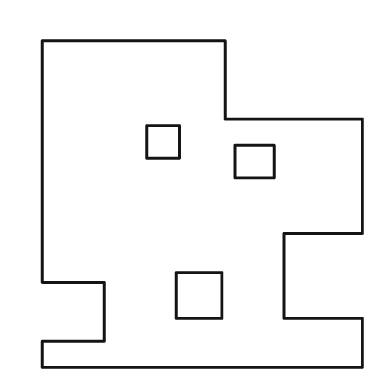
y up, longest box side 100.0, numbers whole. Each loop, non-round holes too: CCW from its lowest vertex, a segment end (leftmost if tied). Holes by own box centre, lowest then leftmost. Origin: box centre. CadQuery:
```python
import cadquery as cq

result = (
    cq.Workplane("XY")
    .moveTo(-49.0, -50.0)
    .lineTo(49.0, -50.0)
    .lineTo(49.0, -35.0)
    .lineTo(25.0, -35.0)
    .lineTo(25.0, -9.0)
    .lineTo(49.0, -9.0)
    .lineTo(49.0, 26.0)
    .lineTo(7.0, 26.0)
    .lineTo(7.0, 50.0)
    .lineTo(-49.0, 50.0)
    .lineTo(-49.0, -24.0)
    .lineTo(-30.0, -24.0)
    .lineTo(-30.0, -42.0)
    .lineTo(-49.0, -42.0)
    .close()
    .moveTo(-8.0, -35.0)
    .lineTo(6.0, -35.0)
    .lineTo(6.0, -21.0)
    .lineTo(-8.0, -21.0)
    .close()
    .moveTo(10.0, 8.0)
    .lineTo(22.0, 8.0)
    .lineTo(22.0, 18.0)
    .lineTo(10.0, 18.0)
    .close()
    .moveTo(-17.0, 14.0)
    .lineTo(-7.0, 14.0)
    .lineTo(-7.0, 24.0)
    .lineTo(-17.0, 24.0)
    .close()
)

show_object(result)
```